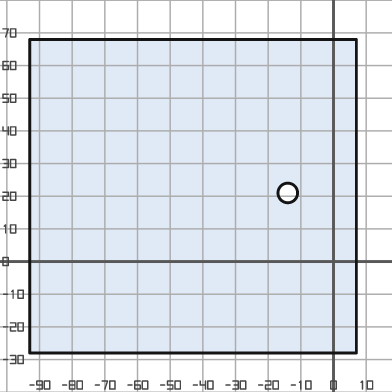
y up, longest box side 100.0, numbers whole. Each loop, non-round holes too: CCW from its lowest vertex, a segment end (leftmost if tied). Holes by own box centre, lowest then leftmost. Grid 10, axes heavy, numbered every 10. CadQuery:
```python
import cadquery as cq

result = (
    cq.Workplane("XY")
    .moveTo(-93.0, -28.0)
    .lineTo(7.0, -28.0)
    .lineTo(7.0, 68.0)
    .lineTo(-93.0, 68.0)
    .close()
    .moveTo(-14.0, 21.0)
    .circle(3.0)
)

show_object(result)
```